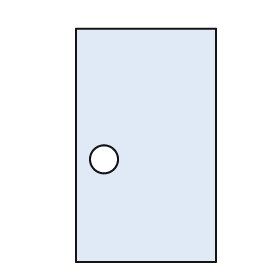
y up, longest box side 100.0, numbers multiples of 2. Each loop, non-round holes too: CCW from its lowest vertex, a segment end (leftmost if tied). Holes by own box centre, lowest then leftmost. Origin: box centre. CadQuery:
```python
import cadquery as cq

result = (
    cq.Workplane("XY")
    .moveTo(-30.0, -50.0)
    .lineTo(30.0, -50.0)
    .lineTo(30.0, 50.0)
    .lineTo(-30.0, 50.0)
    .close()
    .moveTo(-18.0, -6.0)
    .circle(6.0)
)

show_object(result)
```